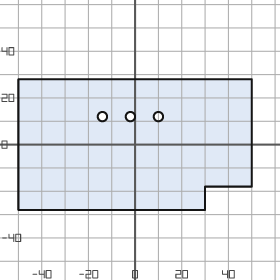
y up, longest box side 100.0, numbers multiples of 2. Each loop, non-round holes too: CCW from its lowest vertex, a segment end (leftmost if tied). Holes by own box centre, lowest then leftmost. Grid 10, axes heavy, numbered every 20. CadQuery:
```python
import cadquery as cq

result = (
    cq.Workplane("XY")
    .moveTo(-50.0, -28.0)
    .lineTo(30.0, -28.0)
    .lineTo(30.0, -18.0)
    .lineTo(50.0, -18.0)
    .lineTo(50.0, 28.0)
    .lineTo(-50.0, 28.0)
    .close()
    .moveTo(-14.0, 12.0)
    .circle(2.0)
    .moveTo(-2.0, 12.0)
    .circle(2.0)
    .moveTo(10.0, 12.0)
    .circle(2.0)
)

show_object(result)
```